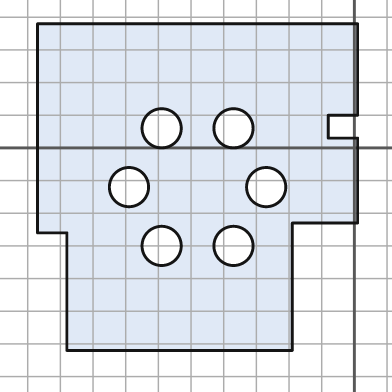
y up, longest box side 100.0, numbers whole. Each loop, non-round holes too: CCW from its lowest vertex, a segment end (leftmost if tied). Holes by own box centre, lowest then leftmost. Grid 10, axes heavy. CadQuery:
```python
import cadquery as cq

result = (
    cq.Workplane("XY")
    .moveTo(-88.0, -62.0)
    .lineTo(-19.0, -62.0)
    .lineTo(-19.0, -23.0)
    .lineTo(1.0, -23.0)
    .lineTo(1.0, 3.0)
    .lineTo(-8.0, 3.0)
    .lineTo(-8.0, 10.0)
    .lineTo(1.0, 10.0)
    .lineTo(1.0, 38.0)
    .lineTo(-97.0, 38.0)
    .lineTo(-97.0, -26.0)
    .lineTo(-88.0, -26.0)
    .close()
    .moveTo(-59.0, -30.0)
    .circle(6.0)
    .moveTo(-37.0, -30.0)
    .circle(6.0)
    .moveTo(-69.0, -12.0)
    .circle(6.0)
    .moveTo(-27.0, -12.0)
    .circle(6.0)
    .moveTo(-59.0, 6.0)
    .circle(6.0)
    .moveTo(-37.0, 6.0)
    .circle(6.0)
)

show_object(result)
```